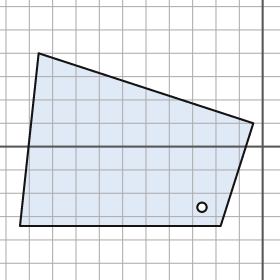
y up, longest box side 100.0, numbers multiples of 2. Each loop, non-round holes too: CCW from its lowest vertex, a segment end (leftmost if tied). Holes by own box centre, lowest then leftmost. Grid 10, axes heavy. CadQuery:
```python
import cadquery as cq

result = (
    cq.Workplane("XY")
    .moveTo(-104.0, -34.0)
    .lineTo(-18.0, -34.0)
    .lineTo(-4.0, 10.0)
    .lineTo(-96.0, 40.0)
    .close()
    .moveTo(-26.0, -26.0)
    .circle(2.0)
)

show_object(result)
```